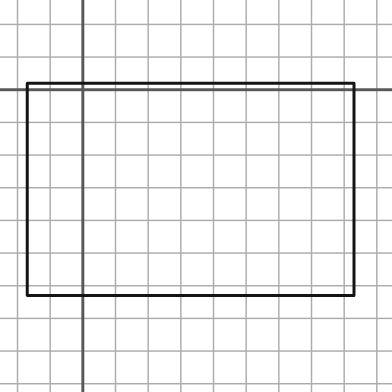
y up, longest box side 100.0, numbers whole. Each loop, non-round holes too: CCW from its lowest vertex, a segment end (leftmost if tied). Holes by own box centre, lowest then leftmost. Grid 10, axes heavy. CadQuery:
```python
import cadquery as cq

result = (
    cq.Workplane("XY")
    .moveTo(-17.0, -63.0)
    .lineTo(83.0, -63.0)
    .lineTo(83.0, 2.0)
    .lineTo(-17.0, 2.0)
    .close()
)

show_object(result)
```